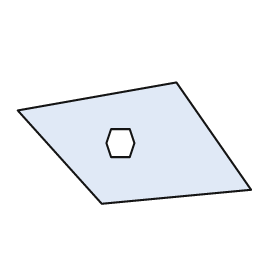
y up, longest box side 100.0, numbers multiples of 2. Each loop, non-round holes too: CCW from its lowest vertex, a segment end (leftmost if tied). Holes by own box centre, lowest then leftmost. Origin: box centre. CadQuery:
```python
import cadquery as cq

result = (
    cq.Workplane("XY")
    .moveTo(-14.0, -26.0)
    .lineTo(50.0, -20.0)
    .lineTo(18.0, 26.0)
    .lineTo(-50.0, 14.0)
    .close()
    .moveTo(-10.0, -6.0)
    .lineTo(-2.0, -6.0)
    .lineTo(0.0, 0.0)
    .lineTo(-2.0, 6.0)
    .lineTo(-10.0, 6.0)
    .lineTo(-12.0, 0.0)
    .close()
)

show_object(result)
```